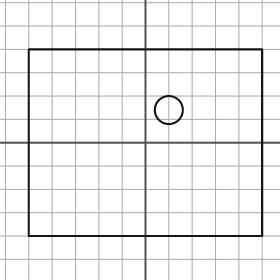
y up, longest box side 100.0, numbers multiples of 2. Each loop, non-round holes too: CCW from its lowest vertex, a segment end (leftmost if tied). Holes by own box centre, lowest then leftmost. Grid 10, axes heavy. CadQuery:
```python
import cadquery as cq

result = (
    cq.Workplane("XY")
    .moveTo(-50.0, -40.0)
    .lineTo(50.0, -40.0)
    .lineTo(50.0, 40.0)
    .lineTo(-50.0, 40.0)
    .close()
    .moveTo(10.0, 14.0)
    .circle(6.0)
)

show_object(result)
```